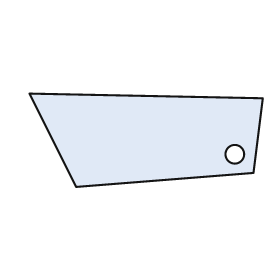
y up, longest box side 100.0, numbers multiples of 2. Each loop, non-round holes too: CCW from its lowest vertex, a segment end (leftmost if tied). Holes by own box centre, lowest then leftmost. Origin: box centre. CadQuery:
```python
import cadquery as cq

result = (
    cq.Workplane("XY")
    .moveTo(-30.0, -20.0)
    .lineTo(46.0, -14.0)
    .lineTo(50.0, 18.0)
    .lineTo(-50.0, 20.0)
    .close()
    .moveTo(38.0, -6.0)
    .circle(4.0)
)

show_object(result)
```